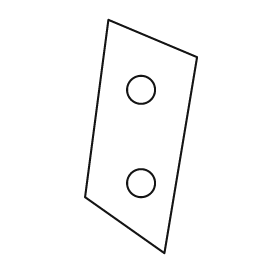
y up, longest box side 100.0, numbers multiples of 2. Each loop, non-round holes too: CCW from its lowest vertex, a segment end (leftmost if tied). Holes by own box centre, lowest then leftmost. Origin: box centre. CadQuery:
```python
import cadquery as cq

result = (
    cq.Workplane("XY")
    .moveTo(10.0, -50.0)
    .lineTo(24.0, 34.0)
    .lineTo(-14.0, 50.0)
    .lineTo(-24.0, -26.0)
    .close()
    .moveTo(0.0, -20.0)
    .circle(6.0)
    .moveTo(0.0, 20.0)
    .circle(6.0)
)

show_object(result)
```